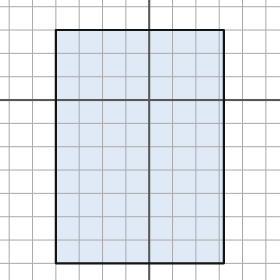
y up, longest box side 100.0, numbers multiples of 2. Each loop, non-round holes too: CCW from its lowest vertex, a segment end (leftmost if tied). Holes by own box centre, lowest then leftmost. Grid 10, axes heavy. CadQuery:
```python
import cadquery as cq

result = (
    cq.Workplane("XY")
    .moveTo(-40.0, -70.0)
    .lineTo(32.0, -70.0)
    .lineTo(32.0, 30.0)
    .lineTo(-40.0, 30.0)
    .close()
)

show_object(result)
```